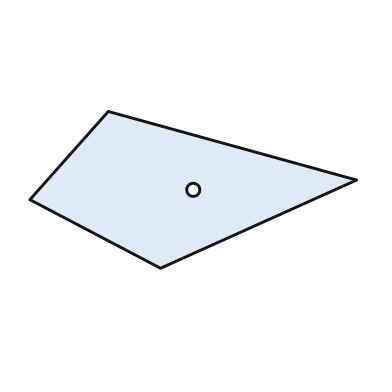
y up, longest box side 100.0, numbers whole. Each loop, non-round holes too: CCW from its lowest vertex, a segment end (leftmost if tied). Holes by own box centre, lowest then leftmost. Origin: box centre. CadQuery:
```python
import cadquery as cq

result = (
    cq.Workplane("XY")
    .moveTo(-10.0, -24.0)
    .lineTo(50.0, 3.0)
    .lineTo(-26.0, 24.0)
    .lineTo(-50.0, -3.0)
    .close()
    .moveTo(0.0, 0.0)
    .circle(2.0)
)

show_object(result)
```